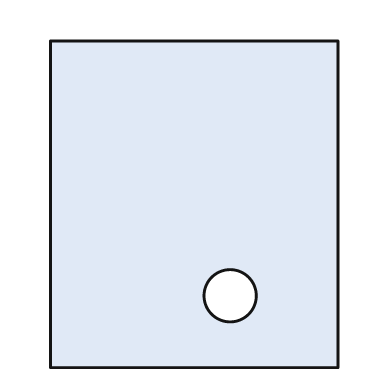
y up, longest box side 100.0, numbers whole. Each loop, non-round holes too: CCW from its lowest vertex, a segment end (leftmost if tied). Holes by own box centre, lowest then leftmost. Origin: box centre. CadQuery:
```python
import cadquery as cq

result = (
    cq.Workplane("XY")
    .moveTo(-44.0, -50.0)
    .lineTo(44.0, -50.0)
    .lineTo(44.0, 50.0)
    .lineTo(-44.0, 50.0)
    .close()
    .moveTo(11.0, -28.0)
    .circle(8.0)
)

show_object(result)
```